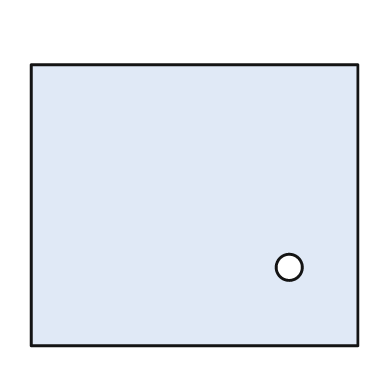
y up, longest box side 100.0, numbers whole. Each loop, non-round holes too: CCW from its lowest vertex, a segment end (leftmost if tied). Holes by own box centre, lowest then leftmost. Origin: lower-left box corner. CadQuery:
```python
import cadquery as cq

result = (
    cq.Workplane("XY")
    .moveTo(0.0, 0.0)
    .lineTo(100.0, 0.0)
    .lineTo(100.0, 86.0)
    .lineTo(0.0, 86.0)
    .close()
    .moveTo(79.0, 24.0)
    .circle(4.0)
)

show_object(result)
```